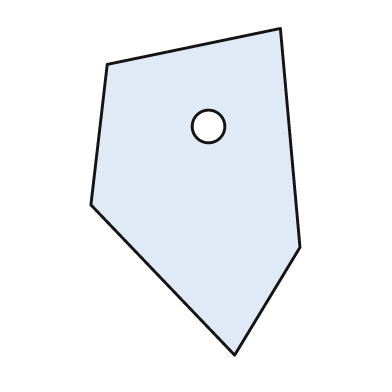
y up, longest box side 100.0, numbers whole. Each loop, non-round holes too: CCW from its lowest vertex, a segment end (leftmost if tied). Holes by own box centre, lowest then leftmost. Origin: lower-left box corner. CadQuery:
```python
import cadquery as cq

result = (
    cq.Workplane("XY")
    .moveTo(44.0, 0.0)
    .lineTo(64.0, 33.0)
    .lineTo(58.0, 100.0)
    .lineTo(5.0, 89.0)
    .lineTo(0.0, 46.0)
    .close()
    .moveTo(36.0, 70.0)
    .circle(5.0)
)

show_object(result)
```